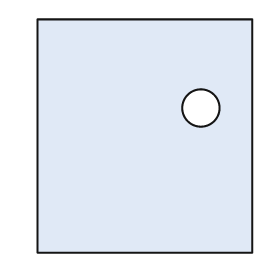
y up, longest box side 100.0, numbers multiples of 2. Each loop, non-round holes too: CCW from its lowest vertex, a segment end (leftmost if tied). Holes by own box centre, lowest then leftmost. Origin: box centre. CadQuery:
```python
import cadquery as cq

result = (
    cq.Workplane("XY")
    .moveTo(-46.0, -50.0)
    .lineTo(46.0, -50.0)
    .lineTo(46.0, 50.0)
    .lineTo(-46.0, 50.0)
    .close()
    .moveTo(24.0, 12.0)
    .circle(8.0)
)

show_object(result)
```